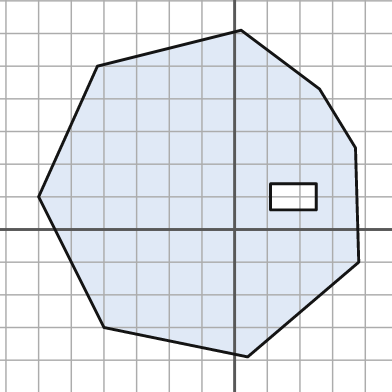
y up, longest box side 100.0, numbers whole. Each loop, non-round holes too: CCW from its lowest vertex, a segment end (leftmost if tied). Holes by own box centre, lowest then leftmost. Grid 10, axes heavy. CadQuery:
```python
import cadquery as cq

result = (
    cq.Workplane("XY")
    .moveTo(4.0, -39.0)
    .lineTo(38.0, -10.0)
    .lineTo(37.0, 25.0)
    .lineTo(26.0, 43.0)
    .lineTo(2.0, 61.0)
    .lineTo(-42.0, 50.0)
    .lineTo(-60.0, 10.0)
    .lineTo(-40.0, -30.0)
    .close()
    .moveTo(11.0, 6.0)
    .lineTo(25.0, 6.0)
    .lineTo(25.0, 14.0)
    .lineTo(11.0, 14.0)
    .close()
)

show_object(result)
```